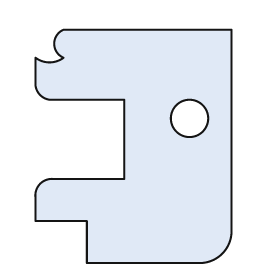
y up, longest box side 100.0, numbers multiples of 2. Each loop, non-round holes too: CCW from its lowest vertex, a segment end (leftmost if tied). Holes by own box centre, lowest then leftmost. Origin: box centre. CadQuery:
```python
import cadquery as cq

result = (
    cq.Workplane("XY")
    .moveTo(-20.0, -50.0)
    .lineTo(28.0, -50.0)
    .threePointArc((38.0, -46.0), (42.0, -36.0))
    .lineTo(42.0, 50.0)
    .lineTo(-30.0, 50.0)
    .threePointArc((-34.0, 44.0), (-30.0, 38.0))
    .threePointArc((-36.0, 36.0), (-42.0, 38.0))
    .lineTo(-42.0, 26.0)
    .threePointArc((-40.0, 22.0), (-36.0, 20.0))
    .lineTo(-4.0, 20.0)
    .lineTo(-4.0, -14.0)
    .lineTo(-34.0, -14.0)
    .threePointArc((-40.0, -16.0), (-42.0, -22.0))
    .lineTo(-42.0, -32.0)
    .lineTo(-20.0, -32.0)
    .close()
    .moveTo(24.0, 12.0)
    .circle(8.0)
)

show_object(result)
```